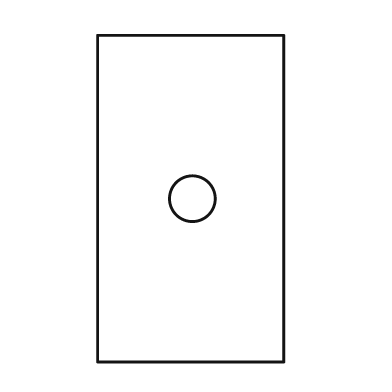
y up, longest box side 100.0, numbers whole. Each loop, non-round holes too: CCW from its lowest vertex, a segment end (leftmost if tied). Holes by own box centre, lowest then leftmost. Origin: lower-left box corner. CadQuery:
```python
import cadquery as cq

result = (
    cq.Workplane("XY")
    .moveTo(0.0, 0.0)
    .lineTo(57.0, 0.0)
    .lineTo(57.0, 100.0)
    .lineTo(0.0, 100.0)
    .close()
    .moveTo(29.0, 50.0)
    .circle(7.0)
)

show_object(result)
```